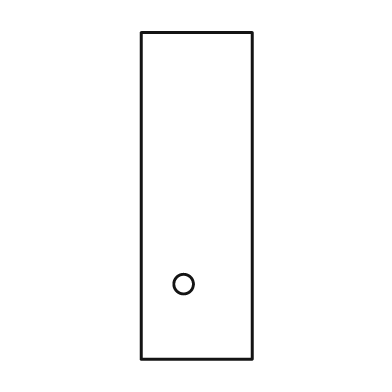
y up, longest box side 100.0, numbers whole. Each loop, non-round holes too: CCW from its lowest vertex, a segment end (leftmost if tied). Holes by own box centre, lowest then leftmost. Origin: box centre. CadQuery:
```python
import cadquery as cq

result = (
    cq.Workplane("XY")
    .moveTo(-17.0, -50.0)
    .lineTo(17.0, -50.0)
    .lineTo(17.0, 50.0)
    .lineTo(-17.0, 50.0)
    .close()
    .moveTo(-4.0, -27.0)
    .circle(3.0)
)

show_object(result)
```